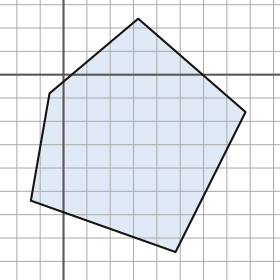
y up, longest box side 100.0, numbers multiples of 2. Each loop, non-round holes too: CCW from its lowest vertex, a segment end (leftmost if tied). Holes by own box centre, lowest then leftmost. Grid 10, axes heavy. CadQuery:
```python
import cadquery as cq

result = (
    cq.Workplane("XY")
    .moveTo(48.0, -76.0)
    .lineTo(78.0, -16.0)
    .lineTo(32.0, 24.0)
    .lineTo(-6.0, -8.0)
    .lineTo(-14.0, -54.0)
    .close()
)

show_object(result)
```